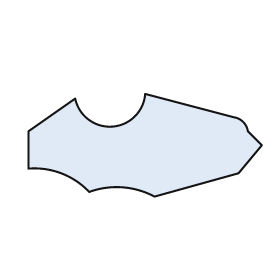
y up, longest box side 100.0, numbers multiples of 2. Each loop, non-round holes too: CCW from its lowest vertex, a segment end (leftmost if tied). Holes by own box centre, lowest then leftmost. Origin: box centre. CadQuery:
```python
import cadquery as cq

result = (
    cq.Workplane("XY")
    .moveTo(4.0, -22.0)
    .lineTo(40.0, -12.0)
    .lineTo(50.0, 0.0)
    .lineTo(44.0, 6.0)
    .threePointArc((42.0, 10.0), (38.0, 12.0))
    .lineTo(0.0, 22.0)
    .threePointArc((-14.0, 8.0), (-30.0, 20.0))
    .lineTo(-50.0, 6.0)
    .lineTo(-50.0, -10.0)
    .threePointArc((-36.0, -12.0), (-24.0, -20.0))
    .threePointArc((-10.0, -18.0), (4.0, -22.0))
    .close()
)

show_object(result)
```